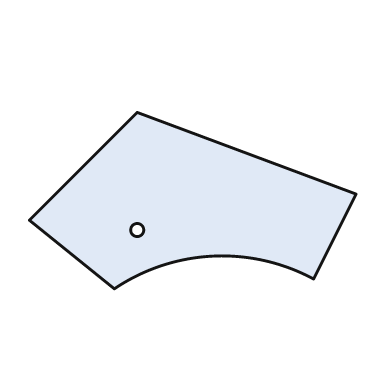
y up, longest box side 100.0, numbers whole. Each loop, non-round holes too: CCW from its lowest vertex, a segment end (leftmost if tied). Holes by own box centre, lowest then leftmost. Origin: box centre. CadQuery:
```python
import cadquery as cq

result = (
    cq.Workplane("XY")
    .moveTo(-24.0, -27.0)
    .threePointArc((6.0, -17.0), (37.0, -24.0))
    .lineTo(50.0, 2.0)
    .lineTo(-17.0, 27.0)
    .lineTo(-50.0, -6.0)
    .close()
    .moveTo(-17.0, -9.0)
    .circle(2.0)
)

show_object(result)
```